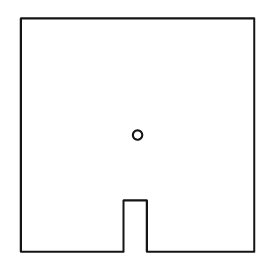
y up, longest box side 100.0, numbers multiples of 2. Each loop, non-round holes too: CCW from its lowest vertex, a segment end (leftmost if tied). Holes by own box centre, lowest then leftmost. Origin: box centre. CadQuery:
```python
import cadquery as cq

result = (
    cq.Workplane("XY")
    .moveTo(-50.0, -50.0)
    .lineTo(-6.0, -50.0)
    .lineTo(-6.0, -28.0)
    .lineTo(4.0, -28.0)
    .lineTo(4.0, -50.0)
    .lineTo(50.0, -50.0)
    .lineTo(50.0, 50.0)
    .lineTo(-50.0, 50.0)
    .close()
    .moveTo(0.0, 0.0)
    .circle(2.0)
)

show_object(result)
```